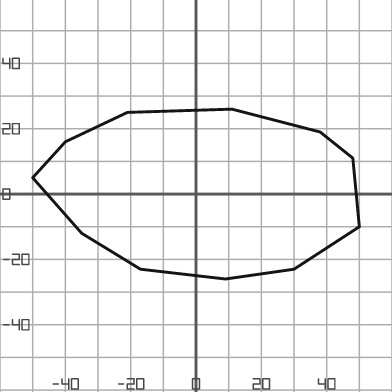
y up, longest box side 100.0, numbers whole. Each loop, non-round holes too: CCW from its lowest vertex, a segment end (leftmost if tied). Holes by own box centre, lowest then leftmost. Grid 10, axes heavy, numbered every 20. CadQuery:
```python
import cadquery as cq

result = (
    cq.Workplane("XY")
    .moveTo(9.0, -26.0)
    .lineTo(30.0, -23.0)
    .lineTo(50.0, -10.0)
    .lineTo(48.0, 11.0)
    .lineTo(38.0, 19.0)
    .lineTo(11.0, 26.0)
    .lineTo(-21.0, 25.0)
    .lineTo(-40.0, 16.0)
    .lineTo(-50.0, 5.0)
    .lineTo(-35.0, -12.0)
    .lineTo(-17.0, -23.0)
    .close()
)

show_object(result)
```